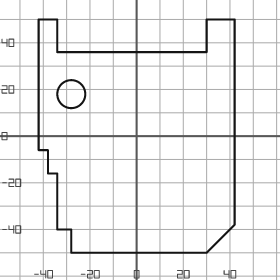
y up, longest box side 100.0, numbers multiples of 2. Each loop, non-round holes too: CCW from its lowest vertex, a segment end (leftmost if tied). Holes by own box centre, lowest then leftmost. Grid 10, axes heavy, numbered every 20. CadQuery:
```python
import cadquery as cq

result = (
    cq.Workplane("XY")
    .moveTo(-28.0, -50.0)
    .lineTo(30.0, -50.0)
    .lineTo(42.0, -38.0)
    .lineTo(42.0, 50.0)
    .lineTo(30.0, 50.0)
    .lineTo(30.0, 36.0)
    .lineTo(-34.0, 36.0)
    .lineTo(-34.0, 50.0)
    .lineTo(-42.0, 50.0)
    .lineTo(-42.0, -6.0)
    .lineTo(-38.0, -6.0)
    .lineTo(-38.0, -16.0)
    .lineTo(-34.0, -16.0)
    .lineTo(-34.0, -40.0)
    .lineTo(-28.0, -40.0)
    .close()
    .moveTo(-28.0, 18.0)
    .circle(6.0)
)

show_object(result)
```